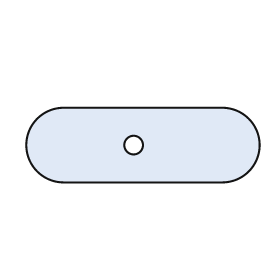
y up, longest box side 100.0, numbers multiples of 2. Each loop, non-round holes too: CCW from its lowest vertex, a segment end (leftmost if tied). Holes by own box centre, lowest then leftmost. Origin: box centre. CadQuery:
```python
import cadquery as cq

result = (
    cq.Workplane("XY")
    .moveTo(-34.0, -16.0)
    .lineTo(34.0, -16.0)
    .threePointArc((50.0, 0.0), (34.0, 16.0))
    .lineTo(-34.0, 16.0)
    .threePointArc((-50.0, 0.0), (-34.0, -16.0))
    .close()
    .moveTo(-4.0, 0.0)
    .circle(4.0)
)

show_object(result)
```